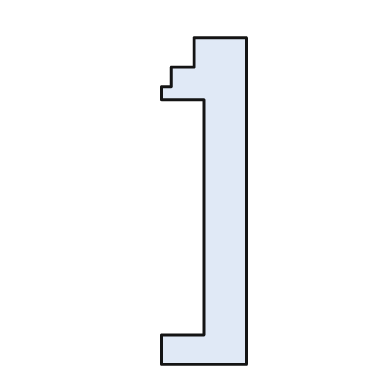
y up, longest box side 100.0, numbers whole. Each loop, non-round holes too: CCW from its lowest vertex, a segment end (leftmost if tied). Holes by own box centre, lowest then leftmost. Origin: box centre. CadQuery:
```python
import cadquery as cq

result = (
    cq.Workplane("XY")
    .moveTo(-13.0, -50.0)
    .lineTo(13.0, -50.0)
    .lineTo(13.0, 50.0)
    .lineTo(-3.0, 50.0)
    .lineTo(-3.0, 41.0)
    .lineTo(-10.0, 41.0)
    .lineTo(-10.0, 35.0)
    .lineTo(-13.0, 35.0)
    .lineTo(-13.0, 31.0)
    .lineTo(0.0, 31.0)
    .lineTo(0.0, -41.0)
    .lineTo(-13.0, -41.0)
    .close()
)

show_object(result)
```